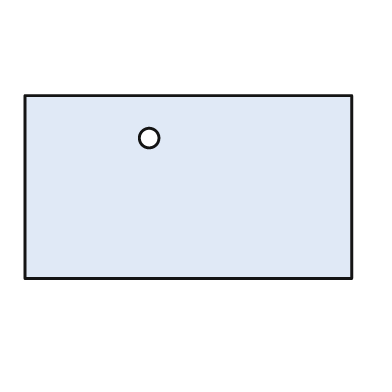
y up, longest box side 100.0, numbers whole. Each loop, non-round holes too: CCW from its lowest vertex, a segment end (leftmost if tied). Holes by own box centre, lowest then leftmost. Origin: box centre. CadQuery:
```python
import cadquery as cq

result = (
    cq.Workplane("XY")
    .moveTo(-50.0, -28.0)
    .lineTo(50.0, -28.0)
    .lineTo(50.0, 28.0)
    .lineTo(-50.0, 28.0)
    .close()
    .moveTo(-12.0, 15.0)
    .circle(3.0)
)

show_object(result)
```